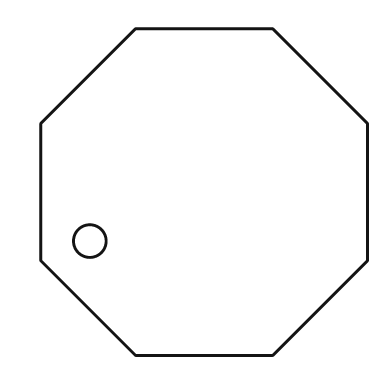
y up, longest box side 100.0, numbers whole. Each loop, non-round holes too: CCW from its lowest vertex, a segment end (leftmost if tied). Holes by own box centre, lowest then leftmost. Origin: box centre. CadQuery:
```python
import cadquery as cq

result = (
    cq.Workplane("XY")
    .moveTo(-21.0, -50.0)
    .lineTo(21.0, -50.0)
    .lineTo(50.0, -21.0)
    .lineTo(50.0, 21.0)
    .lineTo(21.0, 50.0)
    .lineTo(-21.0, 50.0)
    .lineTo(-50.0, 21.0)
    .lineTo(-50.0, -21.0)
    .close()
    .moveTo(-35.0, -15.0)
    .circle(5.0)
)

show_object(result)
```